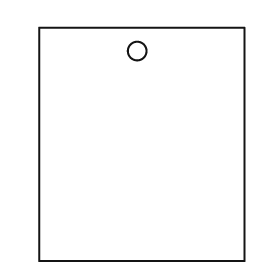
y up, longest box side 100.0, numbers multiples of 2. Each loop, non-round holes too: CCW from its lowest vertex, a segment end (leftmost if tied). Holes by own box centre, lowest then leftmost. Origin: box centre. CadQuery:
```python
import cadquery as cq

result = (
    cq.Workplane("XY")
    .moveTo(-44.0, -50.0)
    .lineTo(44.0, -50.0)
    .lineTo(44.0, 50.0)
    .lineTo(-44.0, 50.0)
    .close()
    .moveTo(-2.0, 40.0)
    .circle(4.0)
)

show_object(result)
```